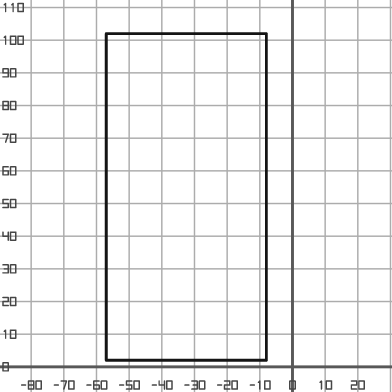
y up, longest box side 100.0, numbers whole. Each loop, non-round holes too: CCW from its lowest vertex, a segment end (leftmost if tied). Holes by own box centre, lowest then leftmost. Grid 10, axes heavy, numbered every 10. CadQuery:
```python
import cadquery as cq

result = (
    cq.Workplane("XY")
    .moveTo(-57.0, 2.0)
    .lineTo(-8.0, 2.0)
    .lineTo(-8.0, 102.0)
    .lineTo(-57.0, 102.0)
    .close()
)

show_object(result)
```